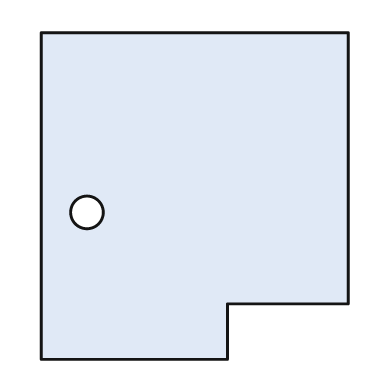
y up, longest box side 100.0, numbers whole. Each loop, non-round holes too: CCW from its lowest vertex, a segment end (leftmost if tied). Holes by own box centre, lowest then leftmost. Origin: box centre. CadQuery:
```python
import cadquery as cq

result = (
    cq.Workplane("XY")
    .moveTo(-47.0, -50.0)
    .lineTo(10.0, -50.0)
    .lineTo(10.0, -33.0)
    .lineTo(47.0, -33.0)
    .lineTo(47.0, 50.0)
    .lineTo(-47.0, 50.0)
    .close()
    .moveTo(-33.0, -5.0)
    .circle(5.0)
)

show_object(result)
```